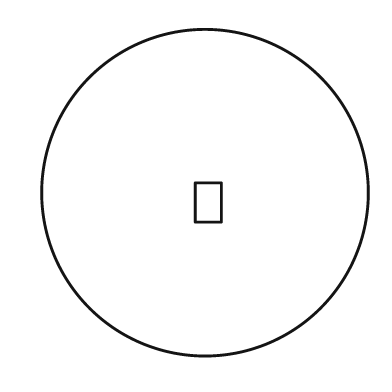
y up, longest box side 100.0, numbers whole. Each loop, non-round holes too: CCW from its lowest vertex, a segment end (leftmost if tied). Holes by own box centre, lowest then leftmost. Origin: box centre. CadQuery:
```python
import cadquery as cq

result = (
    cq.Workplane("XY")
    .moveTo(0.0, 0.0)
    .circle(50.0)
    .moveTo(-3.0, -9.0)
    .lineTo(5.0, -9.0)
    .lineTo(5.0, 3.0)
    .lineTo(-3.0, 3.0)
    .close()
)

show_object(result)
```